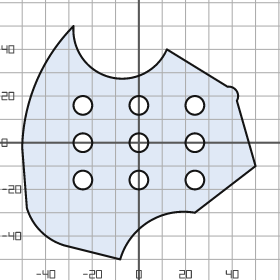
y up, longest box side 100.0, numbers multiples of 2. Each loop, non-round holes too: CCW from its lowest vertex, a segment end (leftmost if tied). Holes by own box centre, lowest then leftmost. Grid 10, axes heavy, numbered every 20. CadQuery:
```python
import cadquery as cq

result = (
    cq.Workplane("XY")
    .moveTo(-8.0, -50.0)
    .threePointArc((4.0, -34.0), (24.0, -30.0))
    .lineTo(50.0, -10.0)
    .lineTo(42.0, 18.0)
    .threePointArc((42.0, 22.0), (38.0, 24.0))
    .lineTo(12.0, 40.0)
    .threePointArc((-12.0, 28.0), (-28.0, 50.0))
    .threePointArc((-44.0, 26.0), (-50.0, -2.0))
    .lineTo(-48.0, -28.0)
    .threePointArc((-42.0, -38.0), (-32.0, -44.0))
    .close()
    .moveTo(-24.0, -16.0)
    .circle(4.0)
    .moveTo(0.0, -16.0)
    .circle(4.0)
    .moveTo(24.0, -16.0)
    .circle(4.0)
    .moveTo(-24.0, 0.0)
    .circle(4.0)
    .moveTo(0.0, 0.0)
    .circle(4.0)
    .moveTo(24.0, 0.0)
    .circle(4.0)
    .moveTo(-24.0, 16.0)
    .circle(4.0)
    .moveTo(0.0, 16.0)
    .circle(4.0)
    .moveTo(24.0, 16.0)
    .circle(4.0)
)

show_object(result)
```